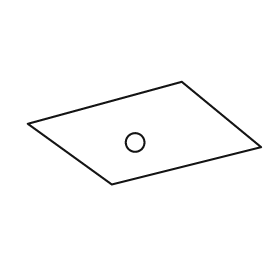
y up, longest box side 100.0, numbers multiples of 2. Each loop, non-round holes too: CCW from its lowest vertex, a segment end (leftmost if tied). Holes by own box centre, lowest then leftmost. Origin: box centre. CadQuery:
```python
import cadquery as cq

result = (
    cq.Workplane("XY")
    .moveTo(-14.0, -22.0)
    .lineTo(50.0, -6.0)
    .lineTo(16.0, 22.0)
    .lineTo(-50.0, 4.0)
    .close()
    .moveTo(-4.0, -4.0)
    .circle(4.0)
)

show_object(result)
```